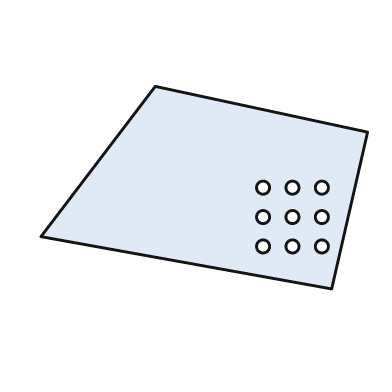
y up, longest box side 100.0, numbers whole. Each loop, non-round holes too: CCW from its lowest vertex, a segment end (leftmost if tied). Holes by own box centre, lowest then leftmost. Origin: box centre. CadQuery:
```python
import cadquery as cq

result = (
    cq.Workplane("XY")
    .moveTo(39.0, -31.0)
    .lineTo(50.0, 17.0)
    .lineTo(-15.0, 31.0)
    .lineTo(-50.0, -15.0)
    .close()
    .moveTo(18.0, -18.0)
    .circle(2.0)
    .moveTo(27.0, -18.0)
    .circle(2.0)
    .moveTo(36.0, -18.0)
    .circle(2.0)
    .moveTo(18.0, -9.0)
    .circle(2.0)
    .moveTo(27.0, -9.0)
    .circle(2.0)
    .moveTo(36.0, -9.0)
    .circle(2.0)
    .moveTo(18.0, 0.0)
    .circle(2.0)
    .moveTo(27.0, 0.0)
    .circle(2.0)
    .moveTo(36.0, 0.0)
    .circle(2.0)
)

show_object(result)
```